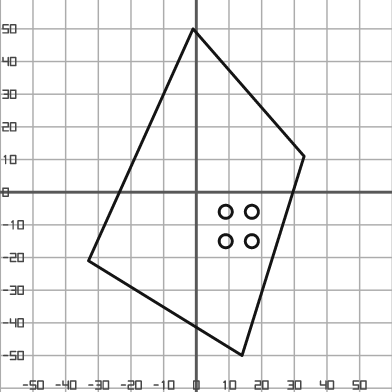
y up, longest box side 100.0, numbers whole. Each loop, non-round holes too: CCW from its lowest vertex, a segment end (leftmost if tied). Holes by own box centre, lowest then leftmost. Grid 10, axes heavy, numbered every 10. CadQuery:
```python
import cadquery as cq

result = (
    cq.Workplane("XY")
    .moveTo(14.0, -50.0)
    .lineTo(33.0, 11.0)
    .lineTo(-1.0, 50.0)
    .lineTo(-33.0, -21.0)
    .close()
    .moveTo(9.0, -15.0)
    .circle(2.0)
    .moveTo(17.0, -15.0)
    .circle(2.0)
    .moveTo(9.0, -6.0)
    .circle(2.0)
    .moveTo(17.0, -6.0)
    .circle(2.0)
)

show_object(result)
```